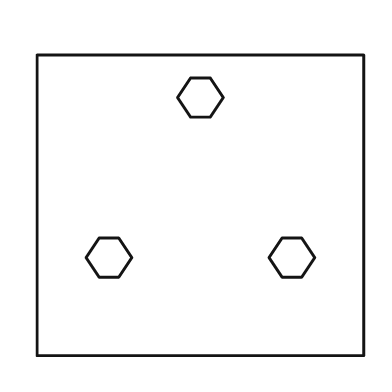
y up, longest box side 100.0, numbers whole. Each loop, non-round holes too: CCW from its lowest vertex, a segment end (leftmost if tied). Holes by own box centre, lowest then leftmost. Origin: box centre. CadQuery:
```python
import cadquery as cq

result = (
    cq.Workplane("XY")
    .moveTo(-50.0, -46.0)
    .lineTo(50.0, -46.0)
    .lineTo(50.0, 46.0)
    .lineTo(-50.0, 46.0)
    .close()
    .moveTo(-31.0, -22.0)
    .lineTo(-25.0, -22.0)
    .lineTo(-21.0, -16.0)
    .lineTo(-25.0, -10.0)
    .lineTo(-31.0, -10.0)
    .lineTo(-35.0, -16.0)
    .close()
    .moveTo(25.0, -22.0)
    .lineTo(31.0, -22.0)
    .lineTo(35.0, -16.0)
    .lineTo(31.0, -10.0)
    .lineTo(25.0, -10.0)
    .lineTo(21.0, -16.0)
    .close()
    .moveTo(-3.0, 27.0)
    .lineTo(3.0, 27.0)
    .lineTo(7.0, 33.0)
    .lineTo(3.0, 39.0)
    .lineTo(-3.0, 39.0)
    .lineTo(-7.0, 33.0)
    .close()
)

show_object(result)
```